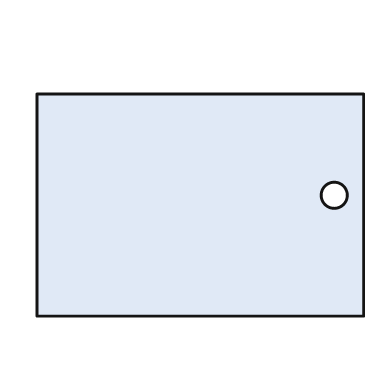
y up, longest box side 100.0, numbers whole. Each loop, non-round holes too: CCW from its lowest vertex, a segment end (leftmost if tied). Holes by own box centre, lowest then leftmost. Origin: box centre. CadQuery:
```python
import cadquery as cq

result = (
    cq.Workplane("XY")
    .moveTo(-50.0, -34.0)
    .lineTo(50.0, -34.0)
    .lineTo(50.0, 34.0)
    .lineTo(-50.0, 34.0)
    .close()
    .moveTo(41.0, 3.0)
    .circle(4.0)
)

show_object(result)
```